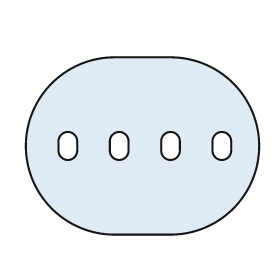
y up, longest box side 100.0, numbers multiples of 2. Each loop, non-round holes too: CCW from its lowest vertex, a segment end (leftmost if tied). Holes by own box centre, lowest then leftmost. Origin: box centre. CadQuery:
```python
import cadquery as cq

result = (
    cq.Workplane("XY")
    .moveTo(-12.0, -38.0)
    .lineTo(12.0, -38.0)
    .threePointArc((50.0, 0.0), (12.0, 38.0))
    .lineTo(-12.0, 38.0)
    .threePointArc((-50.0, 0.0), (-12.0, -38.0))
    .close()
    .moveTo(-36.0, -2.0)
    .threePointArc((-32.0, -6.0), (-28.0, -2.0))
    .lineTo(-28.0, 2.0)
    .threePointArc((-32.0, 6.0), (-36.0, 2.0))
    .close()
    .moveTo(-14.0, -2.0)
    .threePointArc((-10.0, -6.0), (-6.0, -2.0))
    .lineTo(-6.0, 2.0)
    .threePointArc((-10.0, 6.0), (-14.0, 2.0))
    .close()
    .moveTo(8.0, -2.0)
    .threePointArc((12.0, -6.0), (16.0, -2.0))
    .lineTo(16.0, 2.0)
    .threePointArc((12.0, 6.0), (8.0, 2.0))
    .close()
    .moveTo(30.0, -2.0)
    .threePointArc((34.0, -6.0), (38.0, -2.0))
    .lineTo(38.0, 2.0)
    .threePointArc((34.0, 6.0), (30.0, 2.0))
    .close()
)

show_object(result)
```